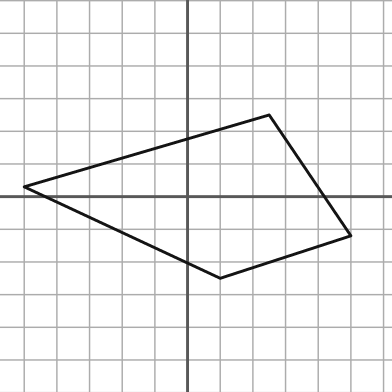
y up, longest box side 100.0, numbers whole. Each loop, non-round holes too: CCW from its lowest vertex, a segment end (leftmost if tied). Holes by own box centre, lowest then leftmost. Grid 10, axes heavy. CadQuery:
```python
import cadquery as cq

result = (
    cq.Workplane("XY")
    .moveTo(10.0, -25.0)
    .lineTo(50.0, -12.0)
    .lineTo(25.0, 25.0)
    .lineTo(-50.0, 3.0)
    .close()
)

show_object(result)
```